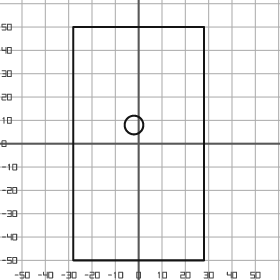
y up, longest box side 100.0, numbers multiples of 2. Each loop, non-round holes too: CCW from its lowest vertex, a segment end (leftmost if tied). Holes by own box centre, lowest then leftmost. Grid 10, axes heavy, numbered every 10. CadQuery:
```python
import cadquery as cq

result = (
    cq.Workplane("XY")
    .moveTo(-28.0, -50.0)
    .lineTo(28.0, -50.0)
    .lineTo(28.0, 50.0)
    .lineTo(-28.0, 50.0)
    .close()
    .moveTo(-2.0, 8.0)
    .circle(4.0)
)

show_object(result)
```